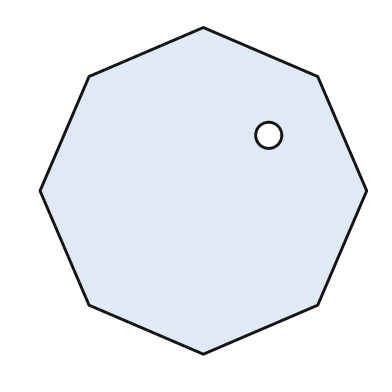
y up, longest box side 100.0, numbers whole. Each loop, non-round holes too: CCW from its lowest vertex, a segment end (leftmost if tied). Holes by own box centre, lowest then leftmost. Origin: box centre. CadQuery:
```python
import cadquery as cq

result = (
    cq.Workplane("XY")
    .moveTo(0.0, -50.0)
    .lineTo(35.0, -35.0)
    .lineTo(50.0, 0.0)
    .lineTo(35.0, 35.0)
    .lineTo(0.0, 50.0)
    .lineTo(-35.0, 35.0)
    .lineTo(-50.0, 0.0)
    .lineTo(-35.0, -35.0)
    .close()
    .moveTo(20.0, 17.0)
    .circle(4.0)
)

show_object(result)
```